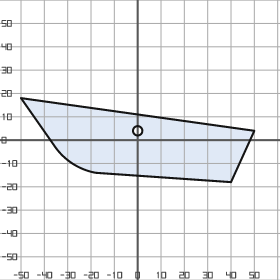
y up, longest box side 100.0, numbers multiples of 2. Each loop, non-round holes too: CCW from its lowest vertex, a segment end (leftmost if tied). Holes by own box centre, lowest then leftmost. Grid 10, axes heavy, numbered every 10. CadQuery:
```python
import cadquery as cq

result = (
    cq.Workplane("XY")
    .moveTo(40.0, -18.0)
    .lineTo(50.0, 4.0)
    .lineTo(-50.0, 18.0)
    .lineTo(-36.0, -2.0)
    .threePointArc((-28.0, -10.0), (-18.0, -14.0))
    .close()
    .moveTo(0.0, 4.0)
    .circle(2.0)
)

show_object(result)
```